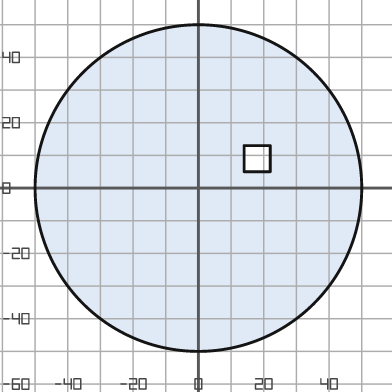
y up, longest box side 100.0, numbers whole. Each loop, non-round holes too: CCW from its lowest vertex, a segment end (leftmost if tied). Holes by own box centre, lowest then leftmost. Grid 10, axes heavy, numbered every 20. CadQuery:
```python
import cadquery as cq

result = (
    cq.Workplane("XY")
    .moveTo(0.0, 0.0)
    .circle(50.0)
    .moveTo(14.0, 5.0)
    .lineTo(22.0, 5.0)
    .lineTo(22.0, 13.0)
    .lineTo(14.0, 13.0)
    .close()
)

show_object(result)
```